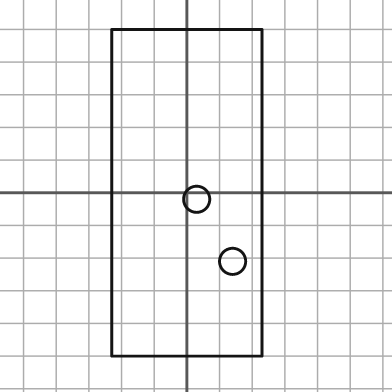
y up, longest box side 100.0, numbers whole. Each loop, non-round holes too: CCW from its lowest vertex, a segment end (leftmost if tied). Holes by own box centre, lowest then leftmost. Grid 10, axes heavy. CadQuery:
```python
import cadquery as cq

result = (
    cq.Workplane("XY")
    .moveTo(-23.0, -50.0)
    .lineTo(23.0, -50.0)
    .lineTo(23.0, 50.0)
    .lineTo(-23.0, 50.0)
    .close()
    .moveTo(14.0, -21.0)
    .circle(4.0)
    .moveTo(3.0, -2.0)
    .circle(4.0)
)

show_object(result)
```